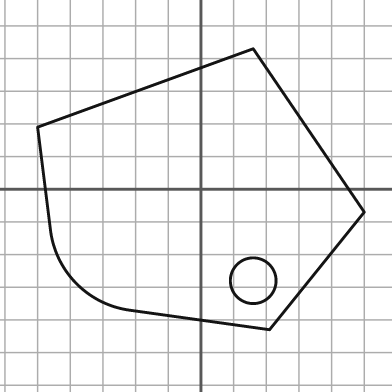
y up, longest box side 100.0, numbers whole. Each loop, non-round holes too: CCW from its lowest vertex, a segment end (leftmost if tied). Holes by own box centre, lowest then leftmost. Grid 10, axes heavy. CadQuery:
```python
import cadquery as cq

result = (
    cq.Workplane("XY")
    .moveTo(21.0, -43.0)
    .lineTo(50.0, -7.0)
    .lineTo(16.0, 43.0)
    .lineTo(-50.0, 19.0)
    .lineTo(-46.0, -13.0)
    .threePointArc((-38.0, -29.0), (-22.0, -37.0))
    .close()
    .moveTo(16.0, -28.0)
    .circle(7.0)
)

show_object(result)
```